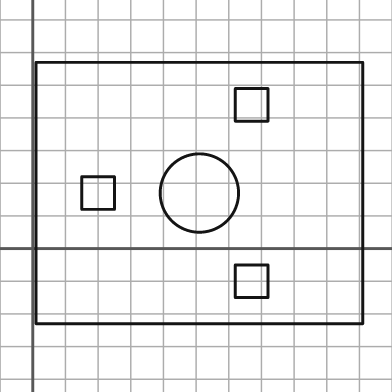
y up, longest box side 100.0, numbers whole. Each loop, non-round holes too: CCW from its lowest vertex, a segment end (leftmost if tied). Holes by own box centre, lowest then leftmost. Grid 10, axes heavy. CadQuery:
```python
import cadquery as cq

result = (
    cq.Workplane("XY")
    .moveTo(1.0, -23.0)
    .lineTo(101.0, -23.0)
    .lineTo(101.0, 57.0)
    .lineTo(1.0, 57.0)
    .close()
    .moveTo(62.0, -15.0)
    .lineTo(72.0, -15.0)
    .lineTo(72.0, -5.0)
    .lineTo(62.0, -5.0)
    .close()
    .moveTo(15.0, 12.0)
    .lineTo(25.0, 12.0)
    .lineTo(25.0, 22.0)
    .lineTo(15.0, 22.0)
    .close()
    .moveTo(51.0, 17.0)
    .circle(12.0)
    .moveTo(62.0, 39.0)
    .lineTo(72.0, 39.0)
    .lineTo(72.0, 49.0)
    .lineTo(62.0, 49.0)
    .close()
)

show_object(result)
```